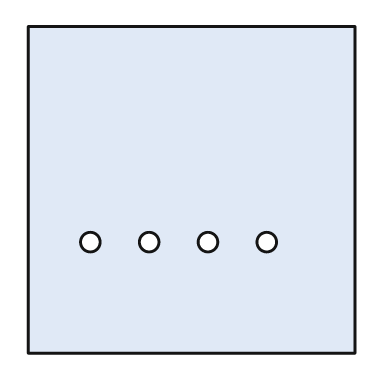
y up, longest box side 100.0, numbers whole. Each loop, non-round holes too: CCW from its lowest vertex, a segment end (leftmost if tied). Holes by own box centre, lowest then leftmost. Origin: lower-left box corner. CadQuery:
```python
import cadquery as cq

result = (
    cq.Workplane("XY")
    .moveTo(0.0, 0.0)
    .lineTo(100.0, 0.0)
    .lineTo(100.0, 100.0)
    .lineTo(0.0, 100.0)
    .close()
    .moveTo(19.0, 34.0)
    .circle(3.0)
    .moveTo(37.0, 34.0)
    .circle(3.0)
    .moveTo(55.0, 34.0)
    .circle(3.0)
    .moveTo(73.0, 34.0)
    .circle(3.0)
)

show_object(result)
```